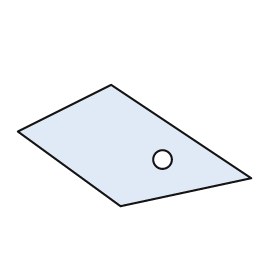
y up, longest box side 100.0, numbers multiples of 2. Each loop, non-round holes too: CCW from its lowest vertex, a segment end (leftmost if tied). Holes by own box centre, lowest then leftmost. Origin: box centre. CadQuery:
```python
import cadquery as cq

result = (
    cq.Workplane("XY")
    .moveTo(-6.0, -26.0)
    .lineTo(50.0, -14.0)
    .lineTo(-10.0, 26.0)
    .lineTo(-50.0, 6.0)
    .close()
    .moveTo(12.0, -6.0)
    .circle(4.0)
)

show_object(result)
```